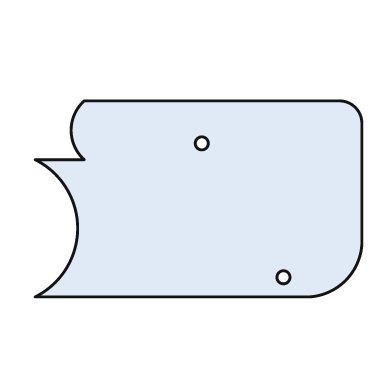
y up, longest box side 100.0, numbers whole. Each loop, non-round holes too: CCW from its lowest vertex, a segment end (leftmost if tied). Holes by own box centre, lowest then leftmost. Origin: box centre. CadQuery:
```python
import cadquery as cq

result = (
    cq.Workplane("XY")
    .moveTo(-50.0, -30.0)
    .lineTo(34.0, -30.0)
    .threePointArc((45.0, -25.0), (50.0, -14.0))
    .lineTo(50.0, 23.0)
    .threePointArc((48.0, 28.0), (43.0, 30.0))
    .lineTo(-35.0, 30.0)
    .threePointArc((-39.0, 21.0), (-35.0, 12.0))
    .lineTo(-50.0, 12.0)
    .threePointArc((-37.0, -9.0), (-50.0, -30.0))
    .close()
    .moveTo(26.0, -24.0)
    .circle(2.0)
    .moveTo(1.0, 17.0)
    .circle(2.0)
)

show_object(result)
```